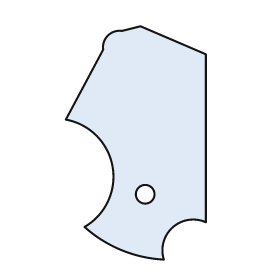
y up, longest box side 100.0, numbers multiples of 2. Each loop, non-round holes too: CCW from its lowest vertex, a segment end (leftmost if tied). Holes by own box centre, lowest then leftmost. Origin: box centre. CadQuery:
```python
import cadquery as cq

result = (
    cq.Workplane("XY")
    .moveTo(12.0, -50.0)
    .threePointArc((16.0, -36.0), (30.0, -34.0))
    .lineTo(30.0, 38.0)
    .lineTo(2.0, 50.0)
    .lineTo(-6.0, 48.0)
    .threePointArc((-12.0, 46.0), (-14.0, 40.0))
    .lineTo(-30.0, 10.0)
    .threePointArc((-10.0, -10.0), (-22.0, -36.0))
    .threePointArc((-6.0, -46.0), (12.0, -50.0))
    .close()
    .moveTo(4.0, -22.0)
    .circle(4.0)
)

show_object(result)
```